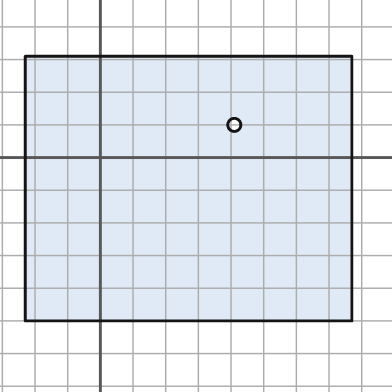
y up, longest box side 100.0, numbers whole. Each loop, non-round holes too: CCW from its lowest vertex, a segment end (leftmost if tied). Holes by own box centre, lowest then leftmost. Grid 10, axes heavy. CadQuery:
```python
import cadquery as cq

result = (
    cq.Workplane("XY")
    .moveTo(-23.0, -50.0)
    .lineTo(77.0, -50.0)
    .lineTo(77.0, 31.0)
    .lineTo(-23.0, 31.0)
    .close()
    .moveTo(41.0, 10.0)
    .circle(2.0)
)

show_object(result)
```